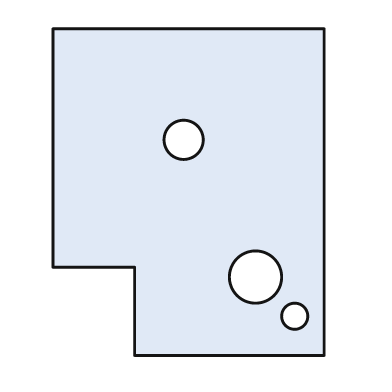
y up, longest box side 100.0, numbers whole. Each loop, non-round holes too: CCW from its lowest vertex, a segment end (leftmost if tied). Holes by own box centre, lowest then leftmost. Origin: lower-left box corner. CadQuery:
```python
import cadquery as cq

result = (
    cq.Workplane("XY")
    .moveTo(25.0, 0.0)
    .lineTo(83.0, 0.0)
    .lineTo(83.0, 100.0)
    .lineTo(0.0, 100.0)
    .lineTo(0.0, 27.0)
    .lineTo(25.0, 27.0)
    .close()
    .moveTo(74.0, 12.0)
    .circle(4.0)
    .moveTo(62.0, 24.0)
    .circle(8.0)
    .moveTo(40.0, 66.0)
    .circle(6.0)
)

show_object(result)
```